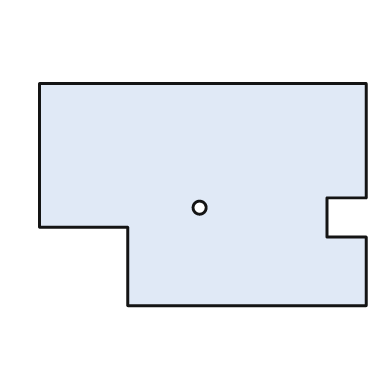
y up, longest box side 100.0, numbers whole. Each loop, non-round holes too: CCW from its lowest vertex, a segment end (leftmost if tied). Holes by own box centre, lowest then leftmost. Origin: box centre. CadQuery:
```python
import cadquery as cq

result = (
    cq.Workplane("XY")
    .moveTo(-23.0, -34.0)
    .lineTo(50.0, -34.0)
    .lineTo(50.0, -13.0)
    .lineTo(38.0, -13.0)
    .lineTo(38.0, -1.0)
    .lineTo(50.0, -1.0)
    .lineTo(50.0, 34.0)
    .lineTo(-50.0, 34.0)
    .lineTo(-50.0, -10.0)
    .lineTo(-23.0, -10.0)
    .close()
    .moveTo(-1.0, -4.0)
    .circle(2.0)
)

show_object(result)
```